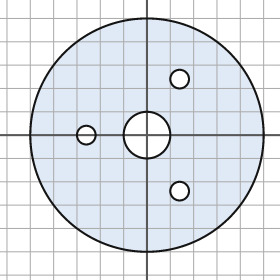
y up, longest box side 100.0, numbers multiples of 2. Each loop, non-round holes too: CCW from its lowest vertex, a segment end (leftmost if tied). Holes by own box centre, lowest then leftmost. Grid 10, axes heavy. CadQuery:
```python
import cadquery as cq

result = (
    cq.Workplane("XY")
    .moveTo(0.0, 0.0)
    .circle(50.0)
    .moveTo(14.0, -24.0)
    .circle(4.0)
    .moveTo(-26.0, 0.0)
    .circle(4.0)
    .moveTo(0.0, 0.0)
    .circle(10.0)
    .moveTo(14.0, 24.0)
    .circle(4.0)
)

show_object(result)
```